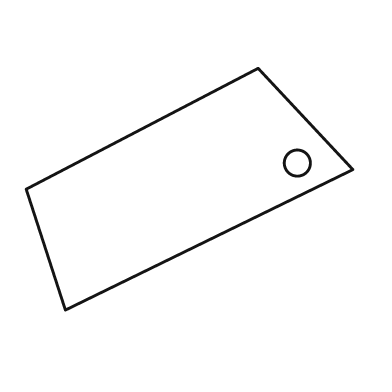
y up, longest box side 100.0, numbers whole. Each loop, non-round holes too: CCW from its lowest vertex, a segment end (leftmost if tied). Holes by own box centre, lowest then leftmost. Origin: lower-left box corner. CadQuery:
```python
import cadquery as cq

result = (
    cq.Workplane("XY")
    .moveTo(12.0, 0.0)
    .lineTo(100.0, 43.0)
    .lineTo(71.0, 74.0)
    .lineTo(0.0, 37.0)
    .close()
    .moveTo(83.0, 45.0)
    .circle(4.0)
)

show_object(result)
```